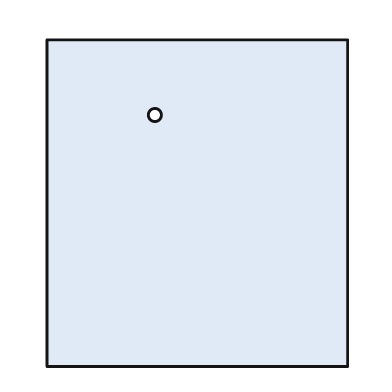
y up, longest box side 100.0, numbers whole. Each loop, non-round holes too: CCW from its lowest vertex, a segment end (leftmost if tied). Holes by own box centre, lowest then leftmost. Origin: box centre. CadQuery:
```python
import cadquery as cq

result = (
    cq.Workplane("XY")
    .moveTo(-46.0, -50.0)
    .lineTo(46.0, -50.0)
    .lineTo(46.0, 50.0)
    .lineTo(-46.0, 50.0)
    .close()
    .moveTo(-13.0, 27.0)
    .circle(2.0)
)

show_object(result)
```